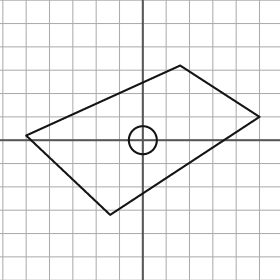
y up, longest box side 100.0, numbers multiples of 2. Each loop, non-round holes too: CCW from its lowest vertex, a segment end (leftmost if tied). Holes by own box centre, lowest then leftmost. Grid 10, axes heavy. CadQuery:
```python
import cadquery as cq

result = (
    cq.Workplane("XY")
    .moveTo(-14.0, -32.0)
    .lineTo(50.0, 10.0)
    .lineTo(16.0, 32.0)
    .lineTo(-50.0, 2.0)
    .close()
    .moveTo(0.0, 0.0)
    .circle(6.0)
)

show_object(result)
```